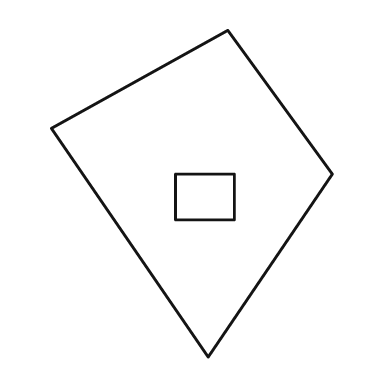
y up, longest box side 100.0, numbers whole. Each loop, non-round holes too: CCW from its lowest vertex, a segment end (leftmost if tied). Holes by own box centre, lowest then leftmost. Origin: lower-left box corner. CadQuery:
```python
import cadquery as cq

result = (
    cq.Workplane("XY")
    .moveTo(48.0, 0.0)
    .lineTo(86.0, 56.0)
    .lineTo(54.0, 100.0)
    .lineTo(0.0, 70.0)
    .close()
    .moveTo(38.0, 42.0)
    .lineTo(56.0, 42.0)
    .lineTo(56.0, 56.0)
    .lineTo(38.0, 56.0)
    .close()
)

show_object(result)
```